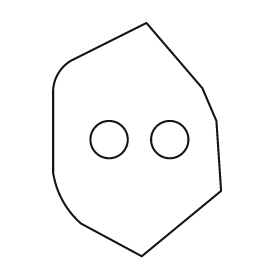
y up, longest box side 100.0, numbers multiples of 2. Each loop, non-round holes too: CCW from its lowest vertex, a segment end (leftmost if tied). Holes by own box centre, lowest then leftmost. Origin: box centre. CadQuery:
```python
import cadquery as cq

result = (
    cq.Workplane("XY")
    .moveTo(2.0, -50.0)
    .lineTo(36.0, -22.0)
    .lineTo(34.0, 8.0)
    .lineTo(28.0, 22.0)
    .lineTo(4.0, 50.0)
    .lineTo(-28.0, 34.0)
    .threePointArc((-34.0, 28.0), (-36.0, 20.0))
    .lineTo(-36.0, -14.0)
    .threePointArc((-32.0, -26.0), (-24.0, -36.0))
    .close()
    .moveTo(-12.0, 0.0)
    .circle(8.0)
    .moveTo(14.0, 0.0)
    .circle(8.0)
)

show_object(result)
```